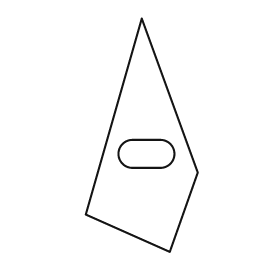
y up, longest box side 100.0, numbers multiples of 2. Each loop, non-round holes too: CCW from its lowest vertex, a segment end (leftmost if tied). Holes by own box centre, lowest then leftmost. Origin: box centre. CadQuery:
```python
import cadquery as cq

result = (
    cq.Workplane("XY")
    .moveTo(12.0, -50.0)
    .lineTo(24.0, -16.0)
    .lineTo(0.0, 50.0)
    .lineTo(-24.0, -34.0)
    .close()
    .moveTo(-4.0, -14.0)
    .lineTo(8.0, -14.0)
    .threePointArc((14.0, -8.0), (8.0, -2.0))
    .lineTo(-4.0, -2.0)
    .threePointArc((-10.0, -8.0), (-4.0, -14.0))
    .close()
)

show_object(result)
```